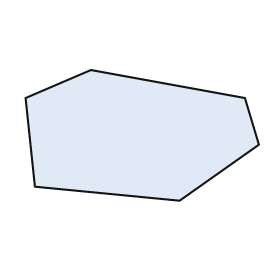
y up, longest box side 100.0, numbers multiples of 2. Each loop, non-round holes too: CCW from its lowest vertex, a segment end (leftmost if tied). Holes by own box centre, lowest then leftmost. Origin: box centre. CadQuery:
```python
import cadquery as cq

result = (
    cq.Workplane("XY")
    .moveTo(16.0, -28.0)
    .lineTo(50.0, -4.0)
    .lineTo(44.0, 16.0)
    .lineTo(-22.0, 28.0)
    .lineTo(-50.0, 16.0)
    .lineTo(-46.0, -22.0)
    .close()
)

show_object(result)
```